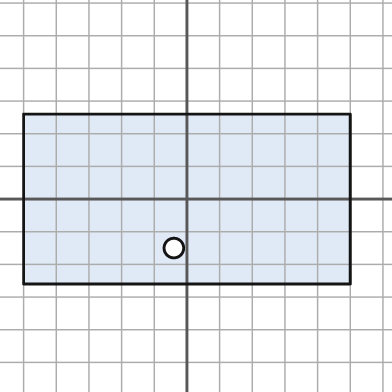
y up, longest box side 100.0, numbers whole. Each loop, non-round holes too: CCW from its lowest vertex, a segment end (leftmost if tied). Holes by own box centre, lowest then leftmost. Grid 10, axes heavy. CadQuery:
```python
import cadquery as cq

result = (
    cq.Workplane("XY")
    .moveTo(-50.0, -26.0)
    .lineTo(50.0, -26.0)
    .lineTo(50.0, 26.0)
    .lineTo(-50.0, 26.0)
    .close()
    .moveTo(-4.0, -15.0)
    .circle(3.0)
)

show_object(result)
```